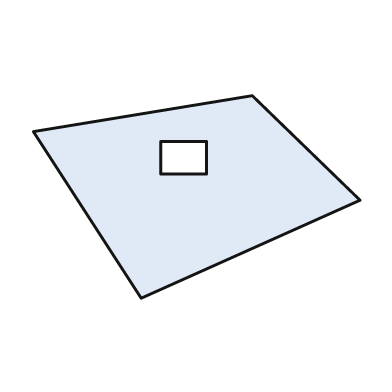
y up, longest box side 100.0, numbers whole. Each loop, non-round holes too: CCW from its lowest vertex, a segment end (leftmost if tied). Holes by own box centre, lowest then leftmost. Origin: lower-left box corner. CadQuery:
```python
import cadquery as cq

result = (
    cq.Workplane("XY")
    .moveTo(33.0, 0.0)
    .lineTo(100.0, 30.0)
    .lineTo(67.0, 62.0)
    .lineTo(0.0, 51.0)
    .close()
    .moveTo(39.0, 38.0)
    .lineTo(53.0, 38.0)
    .lineTo(53.0, 48.0)
    .lineTo(39.0, 48.0)
    .close()
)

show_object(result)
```